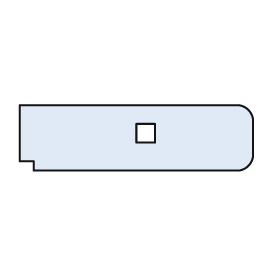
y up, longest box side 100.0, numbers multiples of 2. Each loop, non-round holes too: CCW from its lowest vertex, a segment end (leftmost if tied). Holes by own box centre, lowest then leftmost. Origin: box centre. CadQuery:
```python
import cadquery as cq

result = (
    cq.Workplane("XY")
    .moveTo(-44.0, -14.0)
    .lineTo(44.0, -14.0)
    .threePointArc((48.0, -12.0), (50.0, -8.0))
    .lineTo(50.0, 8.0)
    .threePointArc((48.0, 12.0), (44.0, 14.0))
    .lineTo(-50.0, 14.0)
    .lineTo(-50.0, -10.0)
    .lineTo(-44.0, -10.0)
    .close()
    .moveTo(0.0, -2.0)
    .lineTo(8.0, -2.0)
    .lineTo(8.0, 6.0)
    .lineTo(0.0, 6.0)
    .close()
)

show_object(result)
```